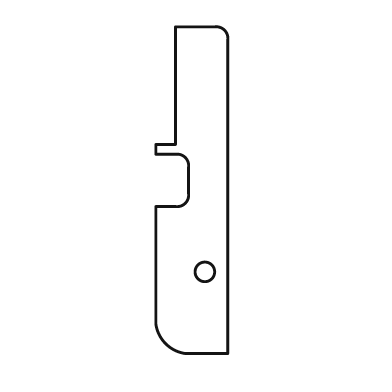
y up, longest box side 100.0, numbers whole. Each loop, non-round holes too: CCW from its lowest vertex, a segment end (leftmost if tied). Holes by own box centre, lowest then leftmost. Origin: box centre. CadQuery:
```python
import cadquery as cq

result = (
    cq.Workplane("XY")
    .moveTo(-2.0, -50.0)
    .lineTo(11.0, -50.0)
    .lineTo(11.0, 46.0)
    .threePointArc((10.0, 49.0), (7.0, 50.0))
    .lineTo(-5.0, 50.0)
    .lineTo(-5.0, 14.0)
    .lineTo(-11.0, 14.0)
    .lineTo(-11.0, 11.0)
    .lineTo(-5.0, 11.0)
    .threePointArc((-2.0, 10.0), (-1.0, 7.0))
    .lineTo(-1.0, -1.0)
    .threePointArc((-2.0, -4.0), (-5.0, -5.0))
    .lineTo(-11.0, -5.0)
    .lineTo(-11.0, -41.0)
    .threePointArc((-8.0, -47.0), (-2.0, -50.0))
    .close()
    .moveTo(4.0, -25.0)
    .circle(3.0)
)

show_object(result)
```